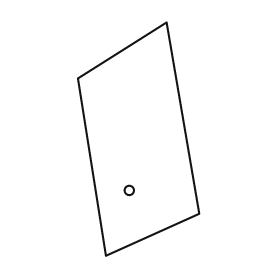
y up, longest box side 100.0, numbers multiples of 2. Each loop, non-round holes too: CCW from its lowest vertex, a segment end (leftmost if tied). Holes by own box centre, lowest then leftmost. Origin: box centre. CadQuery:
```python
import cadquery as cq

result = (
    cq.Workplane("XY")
    .moveTo(-14.0, -50.0)
    .lineTo(26.0, -32.0)
    .lineTo(12.0, 50.0)
    .lineTo(-26.0, 26.0)
    .close()
    .moveTo(-4.0, -22.0)
    .circle(2.0)
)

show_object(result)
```